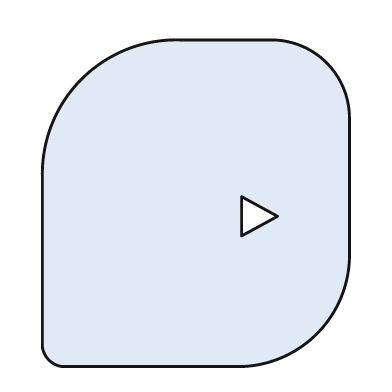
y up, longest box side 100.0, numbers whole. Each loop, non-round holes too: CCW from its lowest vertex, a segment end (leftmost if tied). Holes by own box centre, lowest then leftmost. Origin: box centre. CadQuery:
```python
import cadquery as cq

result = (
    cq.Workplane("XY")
    .moveTo(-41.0, -50.0)
    .lineTo(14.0, -50.0)
    .threePointArc((37.0, -40.0), (47.0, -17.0))
    .lineTo(47.0, 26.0)
    .threePointArc((40.0, 43.0), (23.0, 50.0))
    .lineTo(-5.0, 50.0)
    .threePointArc((-35.0, 38.0), (-47.0, 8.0))
    .lineTo(-47.0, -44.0)
    .threePointArc((-45.0, -48.0), (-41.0, -50.0))
    .close()
    .moveTo(14.0, -10.0)
    .lineTo(25.0, -4.0)
    .lineTo(14.0, 2.0)
    .close()
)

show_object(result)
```